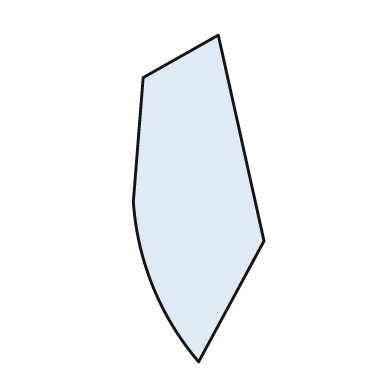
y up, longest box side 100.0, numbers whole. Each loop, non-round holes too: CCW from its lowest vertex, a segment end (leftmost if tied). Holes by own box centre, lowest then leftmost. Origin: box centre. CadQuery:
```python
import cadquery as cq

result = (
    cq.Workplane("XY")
    .moveTo(0.0, -50.0)
    .lineTo(20.0, -13.0)
    .lineTo(6.0, 50.0)
    .lineTo(-17.0, 37.0)
    .lineTo(-20.0, -1.0)
    .threePointArc((-14.0, -27.0), (0.0, -50.0))
    .close()
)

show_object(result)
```